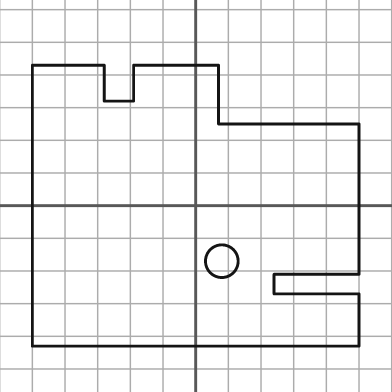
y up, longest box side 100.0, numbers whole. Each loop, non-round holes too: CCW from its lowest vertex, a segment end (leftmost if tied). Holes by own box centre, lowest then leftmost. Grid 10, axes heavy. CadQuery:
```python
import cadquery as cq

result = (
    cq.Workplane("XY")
    .moveTo(-50.0, -43.0)
    .lineTo(50.0, -43.0)
    .lineTo(50.0, -27.0)
    .lineTo(24.0, -27.0)
    .lineTo(24.0, -21.0)
    .lineTo(50.0, -21.0)
    .lineTo(50.0, 25.0)
    .lineTo(7.0, 25.0)
    .lineTo(7.0, 43.0)
    .lineTo(-19.0, 43.0)
    .lineTo(-19.0, 32.0)
    .lineTo(-28.0, 32.0)
    .lineTo(-28.0, 43.0)
    .lineTo(-50.0, 43.0)
    .close()
    .moveTo(8.0, -17.0)
    .circle(5.0)
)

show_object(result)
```